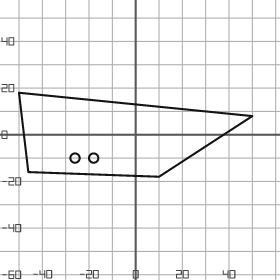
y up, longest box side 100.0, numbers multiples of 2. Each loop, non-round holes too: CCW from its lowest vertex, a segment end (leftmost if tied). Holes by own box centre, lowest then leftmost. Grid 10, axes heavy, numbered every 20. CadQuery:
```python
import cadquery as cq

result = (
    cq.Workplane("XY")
    .moveTo(10.0, -18.0)
    .lineTo(50.0, 8.0)
    .lineTo(-50.0, 18.0)
    .lineTo(-46.0, -16.0)
    .close()
    .moveTo(-26.0, -10.0)
    .circle(2.0)
    .moveTo(-18.0, -10.0)
    .circle(2.0)
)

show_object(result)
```